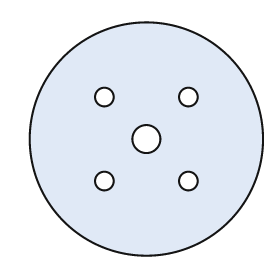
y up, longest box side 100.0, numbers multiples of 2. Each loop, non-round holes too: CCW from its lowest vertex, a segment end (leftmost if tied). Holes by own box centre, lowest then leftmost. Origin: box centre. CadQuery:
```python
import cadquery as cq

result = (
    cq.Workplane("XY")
    .moveTo(0.0, 0.0)
    .circle(50.0)
    .moveTo(-18.0, -18.0)
    .circle(4.0)
    .moveTo(18.0, -18.0)
    .circle(4.0)
    .moveTo(0.0, 0.0)
    .circle(6.0)
    .moveTo(-18.0, 18.0)
    .circle(4.0)
    .moveTo(18.0, 18.0)
    .circle(4.0)
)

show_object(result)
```